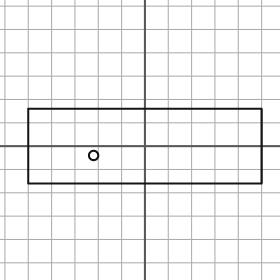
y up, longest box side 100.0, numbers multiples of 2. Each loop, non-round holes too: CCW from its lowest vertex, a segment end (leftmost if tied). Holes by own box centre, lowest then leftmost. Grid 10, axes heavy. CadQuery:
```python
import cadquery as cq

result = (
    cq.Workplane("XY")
    .moveTo(-50.0, -16.0)
    .lineTo(50.0, -16.0)
    .lineTo(50.0, 16.0)
    .lineTo(-50.0, 16.0)
    .close()
    .moveTo(-22.0, -4.0)
    .circle(2.0)
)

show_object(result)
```